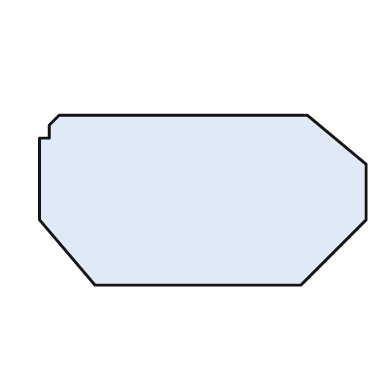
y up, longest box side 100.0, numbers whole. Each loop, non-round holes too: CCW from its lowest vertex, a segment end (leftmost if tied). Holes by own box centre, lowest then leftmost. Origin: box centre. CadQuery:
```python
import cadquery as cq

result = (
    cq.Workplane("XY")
    .moveTo(-33.0, -26.0)
    .lineTo(30.0, -26.0)
    .lineTo(50.0, -6.0)
    .lineTo(50.0, 11.0)
    .lineTo(32.0, 26.0)
    .lineTo(-44.0, 26.0)
    .lineTo(-47.0, 23.0)
    .lineTo(-47.0, 19.0)
    .lineTo(-50.0, 19.0)
    .lineTo(-50.0, -6.0)
    .close()
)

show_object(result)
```